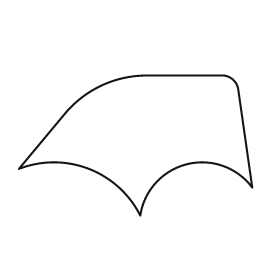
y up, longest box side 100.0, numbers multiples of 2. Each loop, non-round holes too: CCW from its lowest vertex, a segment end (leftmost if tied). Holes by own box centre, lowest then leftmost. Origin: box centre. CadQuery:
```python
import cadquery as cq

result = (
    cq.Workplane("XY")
    .moveTo(2.0, -30.0)
    .threePointArc((22.0, -8.0), (50.0, -18.0))
    .lineTo(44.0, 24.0)
    .threePointArc((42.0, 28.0), (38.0, 30.0))
    .lineTo(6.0, 30.0)
    .threePointArc((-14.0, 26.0), (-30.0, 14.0))
    .lineTo(-50.0, -10.0)
    .threePointArc((-20.0, -10.0), (2.0, -30.0))
    .close()
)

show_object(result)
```